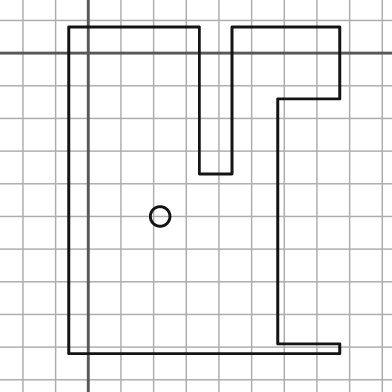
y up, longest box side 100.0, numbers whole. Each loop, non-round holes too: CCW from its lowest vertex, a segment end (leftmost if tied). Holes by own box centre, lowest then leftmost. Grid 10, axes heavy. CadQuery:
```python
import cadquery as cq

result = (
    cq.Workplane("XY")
    .moveTo(-6.0, -92.0)
    .lineTo(77.0, -92.0)
    .lineTo(77.0, -89.0)
    .lineTo(58.0, -89.0)
    .lineTo(58.0, -14.0)
    .lineTo(77.0, -14.0)
    .lineTo(77.0, 8.0)
    .lineTo(44.0, 8.0)
    .lineTo(44.0, -37.0)
    .lineTo(34.0, -37.0)
    .lineTo(34.0, 8.0)
    .lineTo(-6.0, 8.0)
    .close()
    .moveTo(22.0, -50.0)
    .circle(3.0)
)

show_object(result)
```